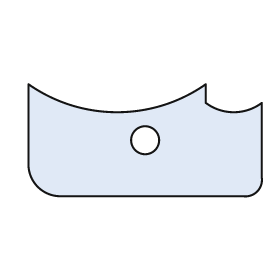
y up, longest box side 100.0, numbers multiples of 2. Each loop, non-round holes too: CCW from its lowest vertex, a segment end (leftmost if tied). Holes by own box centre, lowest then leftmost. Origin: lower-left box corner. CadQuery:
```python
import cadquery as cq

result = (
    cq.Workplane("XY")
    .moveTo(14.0, 0.0)
    .lineTo(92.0, 0.0)
    .threePointArc((98.0, 2.0), (100.0, 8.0))
    .lineTo(100.0, 40.0)
    .threePointArc((88.0, 36.0), (76.0, 40.0))
    .lineTo(76.0, 48.0)
    .threePointArc((38.0, 36.0), (0.0, 48.0))
    .lineTo(0.0, 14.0)
    .threePointArc((4.0, 4.0), (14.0, 0.0))
    .close()
    .moveTo(50.0, 24.0)
    .circle(6.0)
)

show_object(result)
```